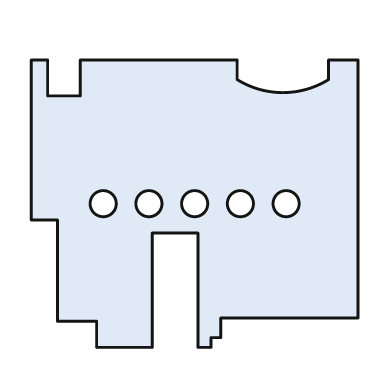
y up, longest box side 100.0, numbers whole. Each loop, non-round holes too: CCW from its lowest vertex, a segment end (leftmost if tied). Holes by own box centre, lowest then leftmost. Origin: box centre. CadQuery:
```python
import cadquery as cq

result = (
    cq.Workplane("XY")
    .moveTo(-30.0, -44.0)
    .lineTo(-13.0, -44.0)
    .lineTo(-13.0, -9.0)
    .lineTo(1.0, -9.0)
    .lineTo(1.0, -44.0)
    .lineTo(5.0, -44.0)
    .lineTo(5.0, -41.0)
    .lineTo(8.0, -41.0)
    .lineTo(8.0, -35.0)
    .lineTo(50.0, -35.0)
    .lineTo(50.0, 44.0)
    .lineTo(41.0, 44.0)
    .lineTo(41.0, 38.0)
    .threePointArc((27.0, 34.0), (13.0, 38.0))
    .lineTo(13.0, 44.0)
    .lineTo(-35.0, 44.0)
    .lineTo(-35.0, 33.0)
    .lineTo(-45.0, 33.0)
    .lineTo(-45.0, 44.0)
    .lineTo(-50.0, 44.0)
    .lineTo(-50.0, -5.0)
    .lineTo(-42.0, -5.0)
    .lineTo(-42.0, -36.0)
    .lineTo(-30.0, -36.0)
    .close()
    .moveTo(-28.0, 0.0)
    .circle(4.0)
    .moveTo(-14.0, 0.0)
    .circle(4.0)
    .moveTo(0.0, 0.0)
    .circle(4.0)
    .moveTo(14.0, 0.0)
    .circle(4.0)
    .moveTo(28.0, 0.0)
    .circle(4.0)
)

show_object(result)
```